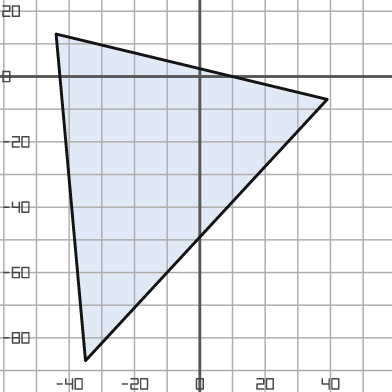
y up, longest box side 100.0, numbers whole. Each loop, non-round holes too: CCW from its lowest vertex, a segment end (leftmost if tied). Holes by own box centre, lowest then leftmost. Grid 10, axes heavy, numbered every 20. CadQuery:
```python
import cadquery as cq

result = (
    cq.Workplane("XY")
    .moveTo(-35.0, -87.0)
    .lineTo(39.0, -7.0)
    .lineTo(-44.0, 13.0)
    .close()
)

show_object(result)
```